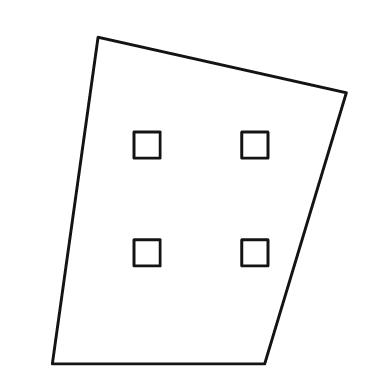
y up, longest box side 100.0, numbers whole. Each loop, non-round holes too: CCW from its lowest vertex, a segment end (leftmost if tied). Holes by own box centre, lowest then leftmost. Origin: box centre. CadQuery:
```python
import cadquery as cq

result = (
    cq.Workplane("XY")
    .moveTo(-45.0, -50.0)
    .lineTo(20.0, -50.0)
    .lineTo(45.0, 33.0)
    .lineTo(-31.0, 50.0)
    .close()
    .moveTo(-20.0, -20.0)
    .lineTo(-12.0, -20.0)
    .lineTo(-12.0, -12.0)
    .lineTo(-20.0, -12.0)
    .close()
    .moveTo(13.0, -20.0)
    .lineTo(21.0, -20.0)
    .lineTo(21.0, -12.0)
    .lineTo(13.0, -12.0)
    .close()
    .moveTo(-20.0, 13.0)
    .lineTo(-12.0, 13.0)
    .lineTo(-12.0, 21.0)
    .lineTo(-20.0, 21.0)
    .close()
    .moveTo(13.0, 13.0)
    .lineTo(21.0, 13.0)
    .lineTo(21.0, 21.0)
    .lineTo(13.0, 21.0)
    .close()
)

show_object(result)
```